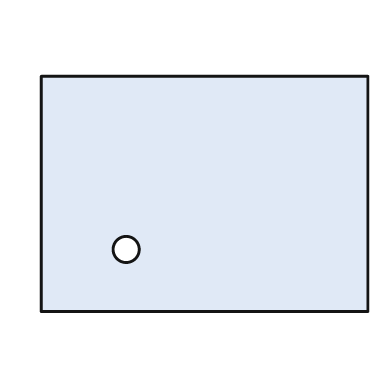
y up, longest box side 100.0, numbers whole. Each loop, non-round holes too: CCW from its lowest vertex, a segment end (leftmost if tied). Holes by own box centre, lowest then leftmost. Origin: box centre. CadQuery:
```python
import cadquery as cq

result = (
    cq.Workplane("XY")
    .moveTo(-50.0, -36.0)
    .lineTo(50.0, -36.0)
    .lineTo(50.0, 36.0)
    .lineTo(-50.0, 36.0)
    .close()
    .moveTo(-24.0, -17.0)
    .circle(4.0)
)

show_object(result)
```